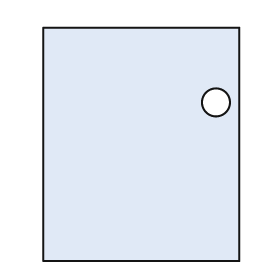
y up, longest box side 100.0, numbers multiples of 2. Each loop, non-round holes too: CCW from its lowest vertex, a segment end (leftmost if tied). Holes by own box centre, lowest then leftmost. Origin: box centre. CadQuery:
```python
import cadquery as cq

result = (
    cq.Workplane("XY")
    .moveTo(-42.0, -50.0)
    .lineTo(42.0, -50.0)
    .lineTo(42.0, 50.0)
    .lineTo(-42.0, 50.0)
    .close()
    .moveTo(32.0, 18.0)
    .circle(6.0)
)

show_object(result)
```